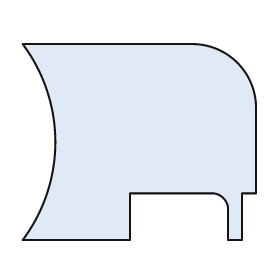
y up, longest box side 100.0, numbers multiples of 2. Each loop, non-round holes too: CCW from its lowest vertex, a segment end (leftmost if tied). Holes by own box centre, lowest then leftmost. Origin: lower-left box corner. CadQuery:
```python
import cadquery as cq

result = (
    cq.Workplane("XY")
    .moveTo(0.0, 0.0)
    .lineTo(46.0, 0.0)
    .lineTo(46.0, 20.0)
    .lineTo(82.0, 20.0)
    .threePointArc((86.0, 18.0), (88.0, 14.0))
    .lineTo(88.0, 0.0)
    .lineTo(94.0, 0.0)
    .lineTo(94.0, 20.0)
    .lineTo(100.0, 20.0)
    .lineTo(100.0, 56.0)
    .threePointArc((92.0, 76.0), (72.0, 84.0))
    .lineTo(0.0, 84.0)
    .threePointArc((14.0, 42.0), (0.0, 0.0))
    .close()
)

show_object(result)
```